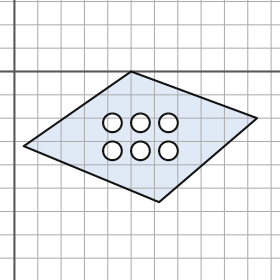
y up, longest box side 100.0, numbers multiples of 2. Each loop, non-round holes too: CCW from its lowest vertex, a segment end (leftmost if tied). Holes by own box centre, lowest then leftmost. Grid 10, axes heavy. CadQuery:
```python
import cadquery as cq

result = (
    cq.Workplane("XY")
    .moveTo(62.0, -56.0)
    .lineTo(104.0, -20.0)
    .lineTo(50.0, 0.0)
    .lineTo(4.0, -32.0)
    .close()
    .moveTo(42.0, -34.0)
    .circle(4.0)
    .moveTo(54.0, -34.0)
    .circle(4.0)
    .moveTo(66.0, -34.0)
    .circle(4.0)
    .moveTo(42.0, -22.0)
    .circle(4.0)
    .moveTo(54.0, -22.0)
    .circle(4.0)
    .moveTo(66.0, -22.0)
    .circle(4.0)
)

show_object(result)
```